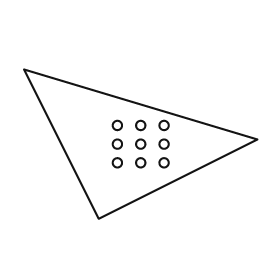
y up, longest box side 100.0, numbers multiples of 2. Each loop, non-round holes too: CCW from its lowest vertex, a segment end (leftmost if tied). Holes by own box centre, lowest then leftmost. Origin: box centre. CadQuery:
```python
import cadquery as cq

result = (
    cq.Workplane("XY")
    .moveTo(-18.0, -32.0)
    .lineTo(50.0, 2.0)
    .lineTo(-50.0, 32.0)
    .close()
    .moveTo(-10.0, -8.0)
    .circle(2.0)
    .moveTo(0.0, -8.0)
    .circle(2.0)
    .moveTo(10.0, -8.0)
    .circle(2.0)
    .moveTo(-10.0, 0.0)
    .circle(2.0)
    .moveTo(0.0, 0.0)
    .circle(2.0)
    .moveTo(10.0, 0.0)
    .circle(2.0)
    .moveTo(-10.0, 8.0)
    .circle(2.0)
    .moveTo(0.0, 8.0)
    .circle(2.0)
    .moveTo(10.0, 8.0)
    .circle(2.0)
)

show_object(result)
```